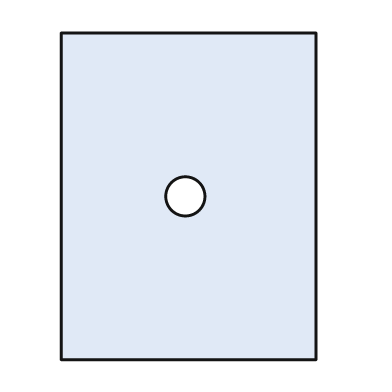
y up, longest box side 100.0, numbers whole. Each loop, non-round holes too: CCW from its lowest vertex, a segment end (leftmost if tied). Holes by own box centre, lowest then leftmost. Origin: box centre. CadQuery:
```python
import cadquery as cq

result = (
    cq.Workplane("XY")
    .moveTo(-39.0, -50.0)
    .lineTo(39.0, -50.0)
    .lineTo(39.0, 50.0)
    .lineTo(-39.0, 50.0)
    .close()
    .moveTo(-1.0, 0.0)
    .circle(6.0)
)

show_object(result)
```